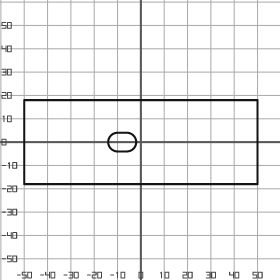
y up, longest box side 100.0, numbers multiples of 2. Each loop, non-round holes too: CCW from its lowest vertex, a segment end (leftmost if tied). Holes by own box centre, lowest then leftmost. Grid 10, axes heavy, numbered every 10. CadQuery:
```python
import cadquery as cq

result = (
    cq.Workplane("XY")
    .moveTo(-50.0, -18.0)
    .lineTo(50.0, -18.0)
    .lineTo(50.0, 18.0)
    .lineTo(-50.0, 18.0)
    .close()
    .moveTo(-10.0, -4.0)
    .lineTo(-6.0, -4.0)
    .threePointArc((-2.0, 0.0), (-6.0, 4.0))
    .lineTo(-10.0, 4.0)
    .threePointArc((-14.0, 0.0), (-10.0, -4.0))
    .close()
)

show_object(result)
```